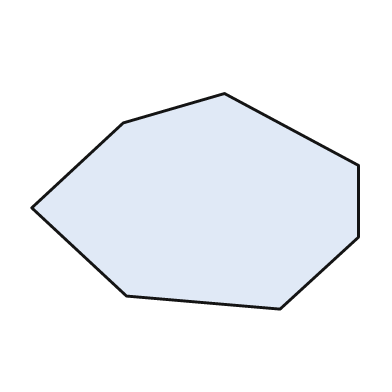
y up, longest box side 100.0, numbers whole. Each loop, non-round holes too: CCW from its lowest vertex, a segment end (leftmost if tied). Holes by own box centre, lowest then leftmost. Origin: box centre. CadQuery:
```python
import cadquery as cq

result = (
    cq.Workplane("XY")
    .moveTo(26.0, -33.0)
    .lineTo(50.0, -11.0)
    .lineTo(50.0, 11.0)
    .lineTo(9.0, 33.0)
    .lineTo(-22.0, 24.0)
    .lineTo(-50.0, -2.0)
    .lineTo(-21.0, -29.0)
    .close()
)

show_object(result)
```